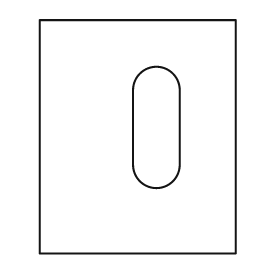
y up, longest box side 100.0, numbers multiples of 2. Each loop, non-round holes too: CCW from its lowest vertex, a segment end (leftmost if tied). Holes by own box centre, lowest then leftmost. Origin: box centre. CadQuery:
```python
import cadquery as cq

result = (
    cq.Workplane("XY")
    .moveTo(-42.0, -50.0)
    .lineTo(42.0, -50.0)
    .lineTo(42.0, 50.0)
    .lineTo(-42.0, 50.0)
    .close()
    .moveTo(-2.0, -12.0)
    .threePointArc((8.0, -22.0), (18.0, -12.0))
    .lineTo(18.0, 20.0)
    .threePointArc((8.0, 30.0), (-2.0, 20.0))
    .close()
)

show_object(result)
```